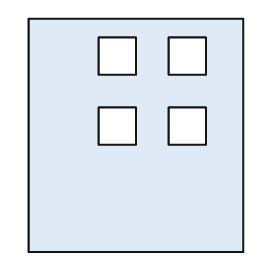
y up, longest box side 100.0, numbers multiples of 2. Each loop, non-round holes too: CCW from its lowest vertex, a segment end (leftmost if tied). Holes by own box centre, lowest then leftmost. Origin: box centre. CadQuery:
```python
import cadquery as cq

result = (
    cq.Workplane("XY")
    .moveTo(-46.0, -50.0)
    .lineTo(46.0, -50.0)
    .lineTo(46.0, 50.0)
    .lineTo(-46.0, 50.0)
    .close()
    .moveTo(-16.0, -4.0)
    .lineTo(0.0, -4.0)
    .lineTo(0.0, 12.0)
    .lineTo(-16.0, 12.0)
    .close()
    .moveTo(14.0, -4.0)
    .lineTo(30.0, -4.0)
    .lineTo(30.0, 12.0)
    .lineTo(14.0, 12.0)
    .close()
    .moveTo(-16.0, 26.0)
    .lineTo(0.0, 26.0)
    .lineTo(0.0, 42.0)
    .lineTo(-16.0, 42.0)
    .close()
    .moveTo(14.0, 26.0)
    .lineTo(30.0, 26.0)
    .lineTo(30.0, 42.0)
    .lineTo(14.0, 42.0)
    .close()
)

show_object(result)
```